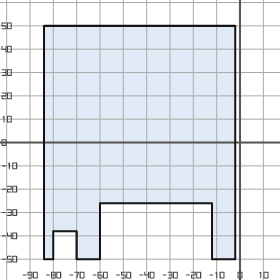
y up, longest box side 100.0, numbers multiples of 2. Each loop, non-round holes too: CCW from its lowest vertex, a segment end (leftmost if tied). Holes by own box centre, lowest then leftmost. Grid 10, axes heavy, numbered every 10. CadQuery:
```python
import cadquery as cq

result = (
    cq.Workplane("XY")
    .moveTo(-84.0, -50.0)
    .lineTo(-80.0, -50.0)
    .lineTo(-80.0, -38.0)
    .lineTo(-70.0, -38.0)
    .lineTo(-70.0, -50.0)
    .lineTo(-60.0, -50.0)
    .lineTo(-60.0, -26.0)
    .lineTo(-12.0, -26.0)
    .lineTo(-12.0, -50.0)
    .lineTo(-2.0, -50.0)
    .lineTo(-2.0, 50.0)
    .lineTo(-84.0, 50.0)
    .close()
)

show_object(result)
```